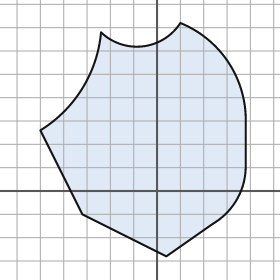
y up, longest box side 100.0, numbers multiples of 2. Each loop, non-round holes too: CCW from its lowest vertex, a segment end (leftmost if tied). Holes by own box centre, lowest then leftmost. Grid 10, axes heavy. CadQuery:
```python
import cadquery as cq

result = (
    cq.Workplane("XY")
    .moveTo(4.0, -28.0)
    .lineTo(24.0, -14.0)
    .threePointArc((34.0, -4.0), (38.0, 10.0))
    .lineTo(38.0, 32.0)
    .threePointArc((30.0, 56.0), (10.0, 72.0))
    .threePointArc((-6.0, 62.0), (-24.0, 68.0))
    .threePointArc((-32.0, 44.0), (-50.0, 26.0))
    .lineTo(-32.0, -10.0)
    .close()
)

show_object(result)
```